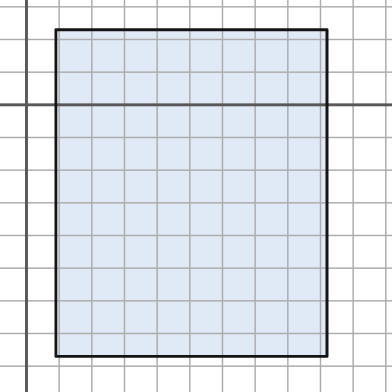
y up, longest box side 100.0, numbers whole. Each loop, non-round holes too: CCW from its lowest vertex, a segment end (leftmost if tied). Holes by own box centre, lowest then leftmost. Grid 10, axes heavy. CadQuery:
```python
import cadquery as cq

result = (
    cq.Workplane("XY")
    .moveTo(9.0, -77.0)
    .lineTo(92.0, -77.0)
    .lineTo(92.0, 23.0)
    .lineTo(9.0, 23.0)
    .close()
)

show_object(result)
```